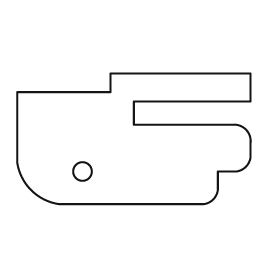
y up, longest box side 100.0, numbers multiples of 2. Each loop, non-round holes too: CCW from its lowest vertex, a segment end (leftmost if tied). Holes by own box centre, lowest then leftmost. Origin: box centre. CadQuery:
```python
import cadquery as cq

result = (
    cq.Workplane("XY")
    .moveTo(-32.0, -28.0)
    .lineTo(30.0, -28.0)
    .threePointArc((34.0, -26.0), (36.0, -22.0))
    .lineTo(36.0, -14.0)
    .lineTo(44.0, -14.0)
    .threePointArc((48.0, -12.0), (50.0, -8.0))
    .lineTo(50.0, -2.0)
    .threePointArc((48.0, 4.0), (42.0, 6.0))
    .lineTo(0.0, 6.0)
    .lineTo(0.0, 16.0)
    .lineTo(50.0, 16.0)
    .lineTo(50.0, 28.0)
    .lineTo(-10.0, 28.0)
    .lineTo(-10.0, 20.0)
    .lineTo(-50.0, 20.0)
    .lineTo(-50.0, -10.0)
    .threePointArc((-44.0, -22.0), (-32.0, -28.0))
    .close()
    .moveTo(-22.0, -14.0)
    .circle(4.0)
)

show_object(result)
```